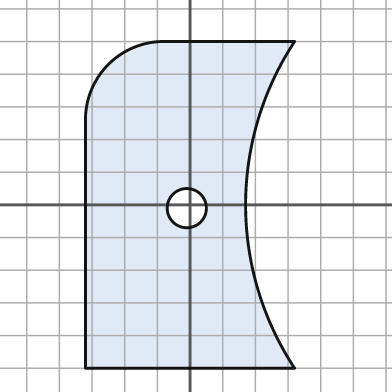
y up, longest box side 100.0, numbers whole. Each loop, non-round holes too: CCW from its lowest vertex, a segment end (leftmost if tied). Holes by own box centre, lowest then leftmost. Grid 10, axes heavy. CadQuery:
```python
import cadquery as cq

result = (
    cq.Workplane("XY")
    .moveTo(-32.0, -50.0)
    .lineTo(32.0, -50.0)
    .threePointArc((17.0, 0.0), (32.0, 50.0))
    .lineTo(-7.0, 50.0)
    .threePointArc((-25.0, 43.0), (-32.0, 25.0))
    .close()
    .moveTo(-1.0, -1.0)
    .circle(6.0)
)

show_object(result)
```